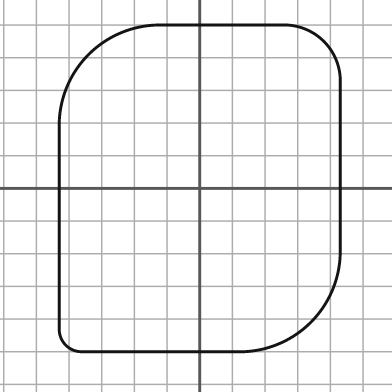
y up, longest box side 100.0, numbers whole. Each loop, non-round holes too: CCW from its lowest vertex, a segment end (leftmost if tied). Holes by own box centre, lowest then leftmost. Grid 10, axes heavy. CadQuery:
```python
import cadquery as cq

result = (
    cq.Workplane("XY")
    .moveTo(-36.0, -50.0)
    .lineTo(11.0, -50.0)
    .threePointArc((34.0, -41.0), (43.0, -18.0))
    .lineTo(43.0, 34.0)
    .threePointArc((38.0, 45.0), (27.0, 50.0))
    .lineTo(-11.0, 50.0)
    .threePointArc((-34.0, 41.0), (-43.0, 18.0))
    .lineTo(-43.0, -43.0)
    .threePointArc((-41.0, -48.0), (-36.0, -50.0))
    .close()
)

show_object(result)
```